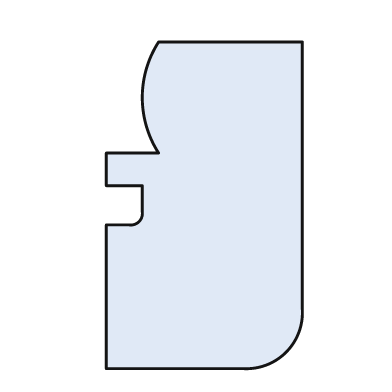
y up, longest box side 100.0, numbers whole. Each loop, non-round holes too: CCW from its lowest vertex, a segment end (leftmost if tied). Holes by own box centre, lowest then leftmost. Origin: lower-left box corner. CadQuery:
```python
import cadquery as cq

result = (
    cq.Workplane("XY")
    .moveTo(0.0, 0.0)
    .lineTo(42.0, 0.0)
    .threePointArc((55.0, 5.0), (60.0, 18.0))
    .lineTo(60.0, 100.0)
    .lineTo(16.0, 100.0)
    .threePointArc((11.0, 83.0), (16.0, 66.0))
    .lineTo(0.0, 66.0)
    .lineTo(0.0, 56.0)
    .lineTo(11.0, 56.0)
    .lineTo(11.0, 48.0)
    .threePointArc((10.0, 45.0), (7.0, 44.0))
    .lineTo(0.0, 44.0)
    .close()
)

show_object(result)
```